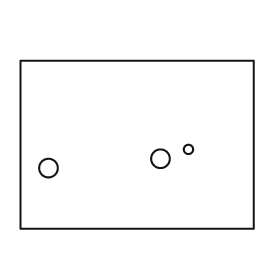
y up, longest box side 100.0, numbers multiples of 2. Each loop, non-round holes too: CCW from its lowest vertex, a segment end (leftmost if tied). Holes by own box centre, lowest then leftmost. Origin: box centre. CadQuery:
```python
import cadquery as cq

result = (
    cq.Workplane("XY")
    .moveTo(-50.0, -36.0)
    .lineTo(50.0, -36.0)
    .lineTo(50.0, 36.0)
    .lineTo(-50.0, 36.0)
    .close()
    .moveTo(-38.0, -10.0)
    .circle(4.0)
    .moveTo(10.0, -6.0)
    .circle(4.0)
    .moveTo(22.0, -2.0)
    .circle(2.0)
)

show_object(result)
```